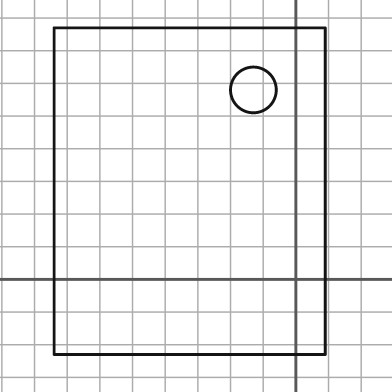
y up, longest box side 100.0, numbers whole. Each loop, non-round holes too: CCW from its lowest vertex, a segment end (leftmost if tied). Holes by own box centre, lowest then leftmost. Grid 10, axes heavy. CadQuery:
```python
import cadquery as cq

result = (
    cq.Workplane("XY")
    .moveTo(-74.0, -23.0)
    .lineTo(9.0, -23.0)
    .lineTo(9.0, 77.0)
    .lineTo(-74.0, 77.0)
    .close()
    .moveTo(-13.0, 58.0)
    .circle(7.0)
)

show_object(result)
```